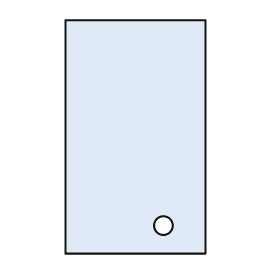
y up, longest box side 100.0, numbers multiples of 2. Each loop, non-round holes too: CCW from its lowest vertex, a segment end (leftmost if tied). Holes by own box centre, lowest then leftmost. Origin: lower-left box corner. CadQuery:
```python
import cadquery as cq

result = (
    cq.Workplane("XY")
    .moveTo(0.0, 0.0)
    .lineTo(60.0, 0.0)
    .lineTo(60.0, 100.0)
    .lineTo(0.0, 100.0)
    .close()
    .moveTo(42.0, 12.0)
    .circle(4.0)
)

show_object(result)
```